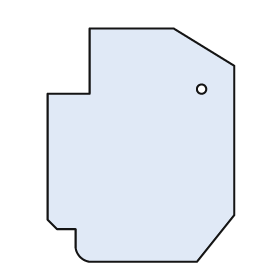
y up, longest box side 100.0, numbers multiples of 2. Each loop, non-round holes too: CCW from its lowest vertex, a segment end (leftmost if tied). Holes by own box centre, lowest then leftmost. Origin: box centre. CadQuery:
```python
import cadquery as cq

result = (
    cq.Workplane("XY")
    .moveTo(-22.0, -50.0)
    .lineTo(24.0, -50.0)
    .lineTo(40.0, -30.0)
    .lineTo(40.0, 34.0)
    .lineTo(14.0, 50.0)
    .lineTo(-22.0, 50.0)
    .lineTo(-22.0, 22.0)
    .lineTo(-40.0, 22.0)
    .lineTo(-40.0, -32.0)
    .lineTo(-36.0, -36.0)
    .lineTo(-28.0, -36.0)
    .lineTo(-28.0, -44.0)
    .threePointArc((-26.0, -48.0), (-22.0, -50.0))
    .close()
    .moveTo(26.0, 24.0)
    .circle(2.0)
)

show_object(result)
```